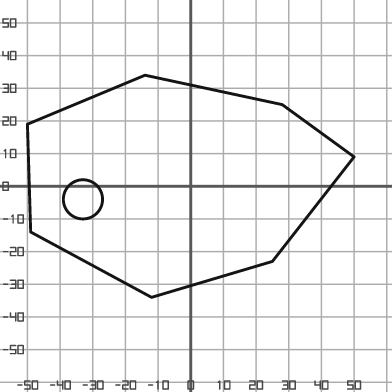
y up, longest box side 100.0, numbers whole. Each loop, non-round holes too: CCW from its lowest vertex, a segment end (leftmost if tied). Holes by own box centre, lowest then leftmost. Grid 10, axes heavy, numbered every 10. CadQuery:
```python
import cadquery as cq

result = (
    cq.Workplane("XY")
    .moveTo(-12.0, -34.0)
    .lineTo(25.0, -23.0)
    .lineTo(50.0, 9.0)
    .lineTo(28.0, 25.0)
    .lineTo(-14.0, 34.0)
    .lineTo(-50.0, 19.0)
    .lineTo(-49.0, -14.0)
    .close()
    .moveTo(-33.0, -4.0)
    .circle(6.0)
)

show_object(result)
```